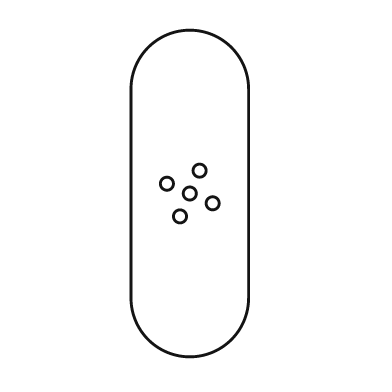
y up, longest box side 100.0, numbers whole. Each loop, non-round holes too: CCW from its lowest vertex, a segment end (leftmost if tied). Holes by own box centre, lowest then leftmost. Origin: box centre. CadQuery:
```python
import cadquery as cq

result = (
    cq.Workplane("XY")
    .moveTo(-18.0, -32.0)
    .threePointArc((0.0, -50.0), (18.0, -32.0))
    .lineTo(18.0, 32.0)
    .threePointArc((0.0, 50.0), (-18.0, 32.0))
    .close()
    .moveTo(-3.0, -7.0)
    .circle(2.0)
    .moveTo(7.0, -3.0)
    .circle(2.0)
    .moveTo(0.0, 0.0)
    .circle(2.0)
    .moveTo(-7.0, 3.0)
    .circle(2.0)
    .moveTo(3.0, 7.0)
    .circle(2.0)
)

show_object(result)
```